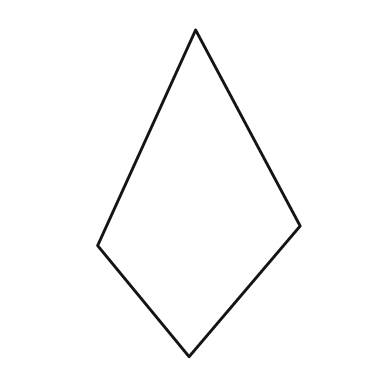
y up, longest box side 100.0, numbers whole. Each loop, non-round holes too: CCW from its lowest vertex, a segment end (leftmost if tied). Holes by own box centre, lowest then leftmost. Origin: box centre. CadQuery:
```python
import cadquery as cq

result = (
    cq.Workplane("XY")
    .moveTo(-3.0, -50.0)
    .lineTo(31.0, -10.0)
    .lineTo(-1.0, 50.0)
    .lineTo(-31.0, -16.0)
    .close()
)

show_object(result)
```